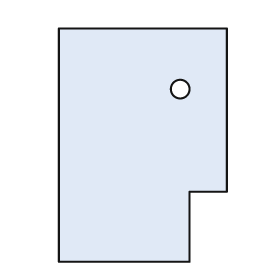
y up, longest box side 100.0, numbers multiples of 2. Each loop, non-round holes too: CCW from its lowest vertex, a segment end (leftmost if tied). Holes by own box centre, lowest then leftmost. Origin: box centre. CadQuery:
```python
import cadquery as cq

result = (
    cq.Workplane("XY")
    .moveTo(-36.0, -50.0)
    .lineTo(20.0, -50.0)
    .lineTo(20.0, -20.0)
    .lineTo(36.0, -20.0)
    .lineTo(36.0, 50.0)
    .lineTo(-36.0, 50.0)
    .close()
    .moveTo(16.0, 24.0)
    .circle(4.0)
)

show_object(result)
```